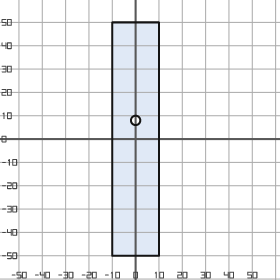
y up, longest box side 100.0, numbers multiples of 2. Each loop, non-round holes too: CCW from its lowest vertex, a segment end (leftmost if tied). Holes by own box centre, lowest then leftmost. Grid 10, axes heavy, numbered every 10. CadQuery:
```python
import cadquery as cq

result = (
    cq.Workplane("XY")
    .moveTo(-10.0, -50.0)
    .lineTo(10.0, -50.0)
    .lineTo(10.0, 50.0)
    .lineTo(-10.0, 50.0)
    .close()
    .moveTo(0.0, 8.0)
    .circle(2.0)
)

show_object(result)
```